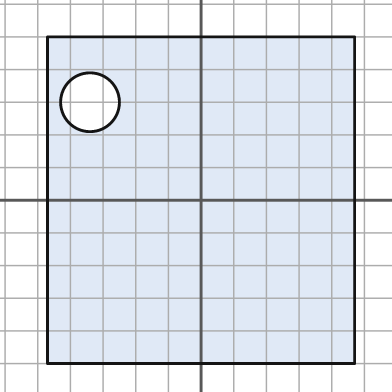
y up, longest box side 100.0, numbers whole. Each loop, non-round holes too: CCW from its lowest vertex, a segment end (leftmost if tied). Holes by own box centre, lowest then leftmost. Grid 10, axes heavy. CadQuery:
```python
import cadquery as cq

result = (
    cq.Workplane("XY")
    .moveTo(-47.0, -50.0)
    .lineTo(47.0, -50.0)
    .lineTo(47.0, 50.0)
    .lineTo(-47.0, 50.0)
    .close()
    .moveTo(-34.0, 30.0)
    .circle(9.0)
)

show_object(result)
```